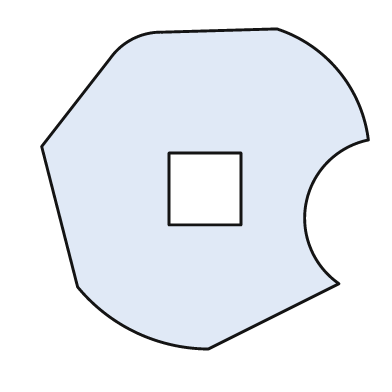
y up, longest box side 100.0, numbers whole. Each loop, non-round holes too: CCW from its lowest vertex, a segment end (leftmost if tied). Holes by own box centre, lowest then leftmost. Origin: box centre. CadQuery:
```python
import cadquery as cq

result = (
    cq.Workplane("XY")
    .moveTo(1.0, -49.0)
    .lineTo(41.0, -29.0)
    .threePointArc((31.0, -4.0), (50.0, 15.0))
    .threePointArc((41.0, 36.0), (22.0, 49.0))
    .lineTo(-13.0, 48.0)
    .threePointArc((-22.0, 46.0), (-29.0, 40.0))
    .lineTo(-50.0, 13.0)
    .lineTo(-39.0, -30.0)
    .threePointArc((-21.0, -44.0), (1.0, -49.0))
    .close()
    .moveTo(-11.0, -11.0)
    .lineTo(11.0, -11.0)
    .lineTo(11.0, 11.0)
    .lineTo(-11.0, 11.0)
    .close()
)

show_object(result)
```